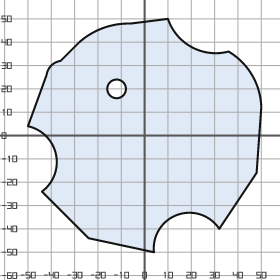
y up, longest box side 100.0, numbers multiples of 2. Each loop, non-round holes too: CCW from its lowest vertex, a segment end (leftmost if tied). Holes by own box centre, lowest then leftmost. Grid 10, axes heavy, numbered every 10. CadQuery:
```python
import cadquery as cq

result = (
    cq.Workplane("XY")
    .moveTo(4.0, -50.0)
    .threePointArc((14.0, -34.0), (32.0, -40.0))
    .lineTo(48.0, -16.0)
    .lineTo(50.0, 12.0)
    .threePointArc((46.0, 26.0), (36.0, 36.0))
    .threePointArc((20.0, 38.0), (10.0, 50.0))
    .lineTo(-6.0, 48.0)
    .threePointArc((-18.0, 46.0), (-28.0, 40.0))
    .lineTo(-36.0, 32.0)
    .threePointArc((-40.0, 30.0), (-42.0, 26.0))
    .lineTo(-50.0, 4.0)
    .threePointArc((-38.0, -8.0), (-44.0, -24.0))
    .lineTo(-24.0, -44.0)
    .close()
    .moveTo(-12.0, 20.0)
    .circle(4.0)
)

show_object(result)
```